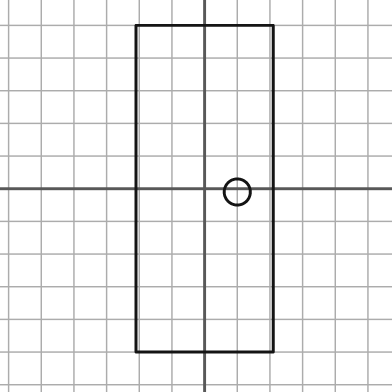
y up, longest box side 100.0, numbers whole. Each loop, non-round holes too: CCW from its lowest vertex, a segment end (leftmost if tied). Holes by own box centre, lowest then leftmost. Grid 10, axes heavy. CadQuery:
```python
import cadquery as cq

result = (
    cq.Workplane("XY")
    .moveTo(-21.0, -50.0)
    .lineTo(21.0, -50.0)
    .lineTo(21.0, 50.0)
    .lineTo(-21.0, 50.0)
    .close()
    .moveTo(10.0, -1.0)
    .circle(4.0)
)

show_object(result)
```